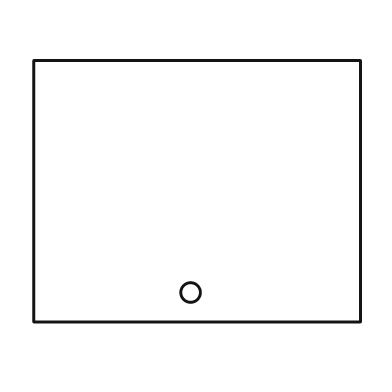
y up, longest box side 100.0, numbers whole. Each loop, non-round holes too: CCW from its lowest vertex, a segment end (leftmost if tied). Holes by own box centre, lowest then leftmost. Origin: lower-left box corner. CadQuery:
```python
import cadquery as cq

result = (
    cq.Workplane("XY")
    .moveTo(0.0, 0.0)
    .lineTo(100.0, 0.0)
    .lineTo(100.0, 80.0)
    .lineTo(0.0, 80.0)
    .close()
    .moveTo(48.0, 9.0)
    .circle(3.0)
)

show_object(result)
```